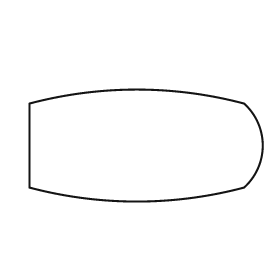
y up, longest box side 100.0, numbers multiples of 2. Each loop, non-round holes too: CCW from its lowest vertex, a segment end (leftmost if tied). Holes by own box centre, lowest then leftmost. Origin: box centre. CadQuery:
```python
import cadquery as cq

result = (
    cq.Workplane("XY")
    .moveTo(-50.0, -18.0)
    .threePointArc((-4.0, -24.0), (42.0, -18.0))
    .threePointArc((50.0, 0.0), (42.0, 18.0))
    .threePointArc((-4.0, 24.0), (-50.0, 18.0))
    .close()
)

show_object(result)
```